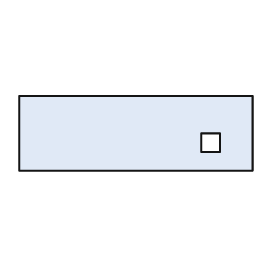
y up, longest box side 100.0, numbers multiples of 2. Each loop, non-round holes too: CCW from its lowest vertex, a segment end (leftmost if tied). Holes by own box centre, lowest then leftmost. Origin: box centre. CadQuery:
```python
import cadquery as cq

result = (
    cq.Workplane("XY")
    .moveTo(-50.0, -16.0)
    .lineTo(50.0, -16.0)
    .lineTo(50.0, 16.0)
    .lineTo(-50.0, 16.0)
    .close()
    .moveTo(28.0, -8.0)
    .lineTo(36.0, -8.0)
    .lineTo(36.0, 0.0)
    .lineTo(28.0, 0.0)
    .close()
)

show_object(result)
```